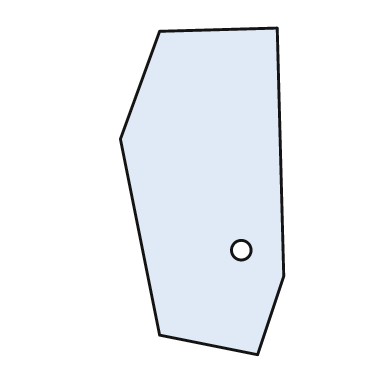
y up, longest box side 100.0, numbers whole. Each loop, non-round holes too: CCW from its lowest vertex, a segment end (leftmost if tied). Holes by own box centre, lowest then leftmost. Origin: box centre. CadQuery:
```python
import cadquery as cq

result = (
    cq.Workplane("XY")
    .moveTo(17.0, -50.0)
    .lineTo(25.0, -26.0)
    .lineTo(23.0, 50.0)
    .lineTo(-13.0, 49.0)
    .lineTo(-25.0, 16.0)
    .lineTo(-13.0, -44.0)
    .close()
    .moveTo(12.0, -18.0)
    .circle(3.0)
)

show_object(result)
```